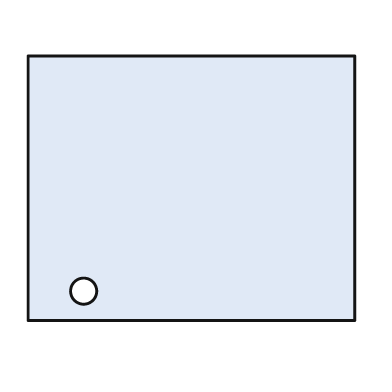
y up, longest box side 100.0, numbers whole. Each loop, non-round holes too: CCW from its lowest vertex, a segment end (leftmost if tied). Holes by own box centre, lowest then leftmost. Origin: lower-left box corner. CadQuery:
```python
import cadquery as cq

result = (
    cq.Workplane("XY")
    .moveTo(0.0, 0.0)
    .lineTo(100.0, 0.0)
    .lineTo(100.0, 81.0)
    .lineTo(0.0, 81.0)
    .close()
    .moveTo(17.0, 9.0)
    .circle(4.0)
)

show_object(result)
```